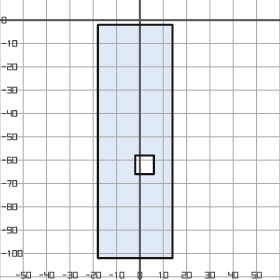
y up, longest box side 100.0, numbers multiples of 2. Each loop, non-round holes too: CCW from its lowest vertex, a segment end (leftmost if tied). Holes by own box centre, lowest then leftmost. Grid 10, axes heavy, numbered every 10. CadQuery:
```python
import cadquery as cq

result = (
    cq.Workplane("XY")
    .moveTo(-18.0, -102.0)
    .lineTo(14.0, -102.0)
    .lineTo(14.0, -2.0)
    .lineTo(-18.0, -2.0)
    .close()
    .moveTo(-2.0, -66.0)
    .lineTo(6.0, -66.0)
    .lineTo(6.0, -58.0)
    .lineTo(-2.0, -58.0)
    .close()
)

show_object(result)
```